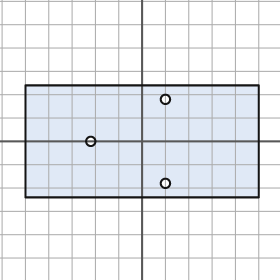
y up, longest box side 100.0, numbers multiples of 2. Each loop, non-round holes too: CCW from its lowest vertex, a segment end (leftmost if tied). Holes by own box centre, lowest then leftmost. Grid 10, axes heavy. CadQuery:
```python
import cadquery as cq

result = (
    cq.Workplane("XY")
    .moveTo(-50.0, -24.0)
    .lineTo(50.0, -24.0)
    .lineTo(50.0, 24.0)
    .lineTo(-50.0, 24.0)
    .close()
    .moveTo(10.0, -18.0)
    .circle(2.0)
    .moveTo(-22.0, 0.0)
    .circle(2.0)
    .moveTo(10.0, 18.0)
    .circle(2.0)
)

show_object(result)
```